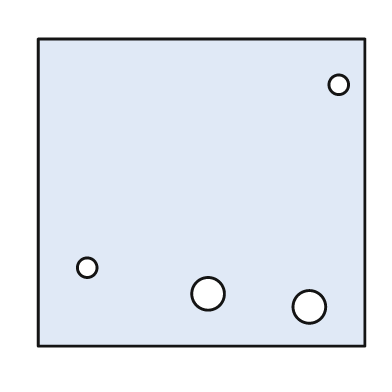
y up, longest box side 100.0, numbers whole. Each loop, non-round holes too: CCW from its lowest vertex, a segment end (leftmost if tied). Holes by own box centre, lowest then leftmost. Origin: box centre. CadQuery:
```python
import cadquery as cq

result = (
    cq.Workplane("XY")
    .moveTo(-50.0, -47.0)
    .lineTo(50.0, -47.0)
    .lineTo(50.0, 47.0)
    .lineTo(-50.0, 47.0)
    .close()
    .moveTo(33.0, -35.0)
    .circle(5.0)
    .moveTo(2.0, -31.0)
    .circle(5.0)
    .moveTo(-35.0, -23.0)
    .circle(3.0)
    .moveTo(42.0, 33.0)
    .circle(3.0)
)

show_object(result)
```